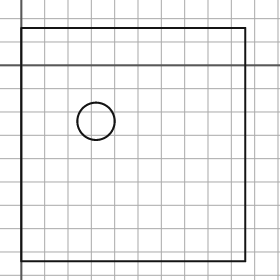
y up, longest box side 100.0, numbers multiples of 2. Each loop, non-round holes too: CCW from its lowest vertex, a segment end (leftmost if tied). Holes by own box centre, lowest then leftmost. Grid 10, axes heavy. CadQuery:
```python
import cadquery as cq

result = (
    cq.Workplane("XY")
    .moveTo(0.0, -84.0)
    .lineTo(96.0, -84.0)
    .lineTo(96.0, 16.0)
    .lineTo(0.0, 16.0)
    .close()
    .moveTo(32.0, -24.0)
    .circle(8.0)
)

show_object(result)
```